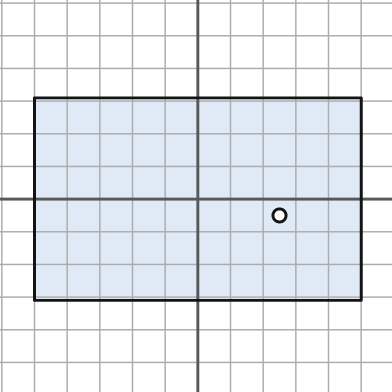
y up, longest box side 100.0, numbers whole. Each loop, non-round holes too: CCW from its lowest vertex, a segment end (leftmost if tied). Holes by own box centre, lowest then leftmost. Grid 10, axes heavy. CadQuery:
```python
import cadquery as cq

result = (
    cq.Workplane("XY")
    .moveTo(-50.0, -31.0)
    .lineTo(50.0, -31.0)
    .lineTo(50.0, 31.0)
    .lineTo(-50.0, 31.0)
    .close()
    .moveTo(25.0, -5.0)
    .circle(2.0)
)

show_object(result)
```